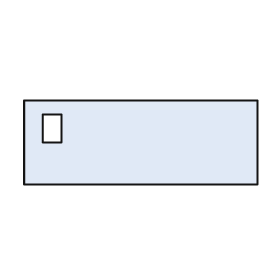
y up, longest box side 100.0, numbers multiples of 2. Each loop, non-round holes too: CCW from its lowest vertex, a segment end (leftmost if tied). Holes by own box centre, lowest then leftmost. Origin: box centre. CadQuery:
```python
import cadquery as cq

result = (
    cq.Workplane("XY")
    .moveTo(-50.0, -18.0)
    .lineTo(50.0, -18.0)
    .lineTo(50.0, 18.0)
    .lineTo(-50.0, 18.0)
    .close()
    .moveTo(-42.0, 0.0)
    .lineTo(-34.0, 0.0)
    .lineTo(-34.0, 12.0)
    .lineTo(-42.0, 12.0)
    .close()
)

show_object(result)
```